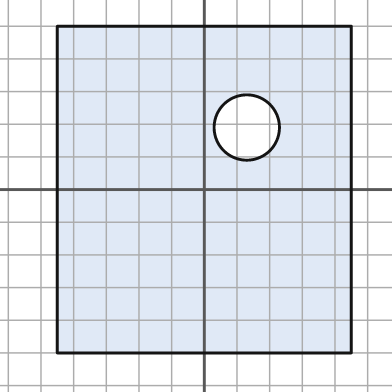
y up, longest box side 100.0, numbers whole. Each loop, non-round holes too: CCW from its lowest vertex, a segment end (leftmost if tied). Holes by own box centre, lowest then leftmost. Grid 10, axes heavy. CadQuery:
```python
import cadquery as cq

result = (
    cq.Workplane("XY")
    .moveTo(-45.0, -50.0)
    .lineTo(45.0, -50.0)
    .lineTo(45.0, 50.0)
    .lineTo(-45.0, 50.0)
    .close()
    .moveTo(13.0, 19.0)
    .circle(10.0)
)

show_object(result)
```